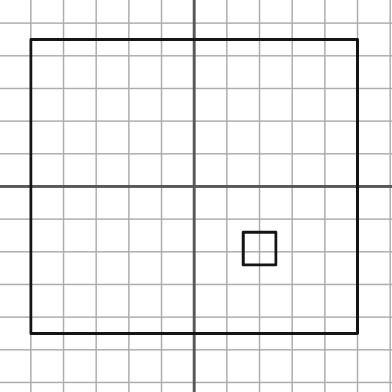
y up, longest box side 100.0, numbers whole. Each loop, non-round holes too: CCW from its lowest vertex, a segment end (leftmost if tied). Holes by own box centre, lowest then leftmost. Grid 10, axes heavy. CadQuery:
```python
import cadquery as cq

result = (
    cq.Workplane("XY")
    .moveTo(-50.0, -45.0)
    .lineTo(50.0, -45.0)
    .lineTo(50.0, 45.0)
    .lineTo(-50.0, 45.0)
    .close()
    .moveTo(15.0, -24.0)
    .lineTo(25.0, -24.0)
    .lineTo(25.0, -14.0)
    .lineTo(15.0, -14.0)
    .close()
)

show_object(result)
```